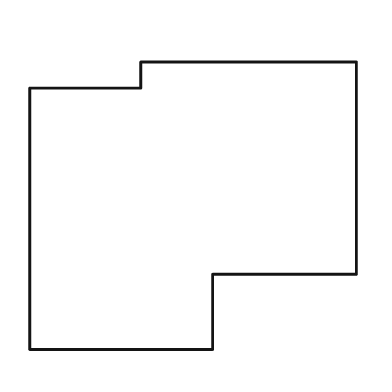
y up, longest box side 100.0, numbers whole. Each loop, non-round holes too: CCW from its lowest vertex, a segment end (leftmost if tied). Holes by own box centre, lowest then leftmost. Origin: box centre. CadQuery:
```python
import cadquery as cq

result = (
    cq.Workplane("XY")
    .moveTo(-50.0, -44.0)
    .lineTo(6.0, -44.0)
    .lineTo(6.0, -21.0)
    .lineTo(50.0, -21.0)
    .lineTo(50.0, 44.0)
    .lineTo(-16.0, 44.0)
    .lineTo(-16.0, 36.0)
    .lineTo(-50.0, 36.0)
    .close()
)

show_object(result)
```